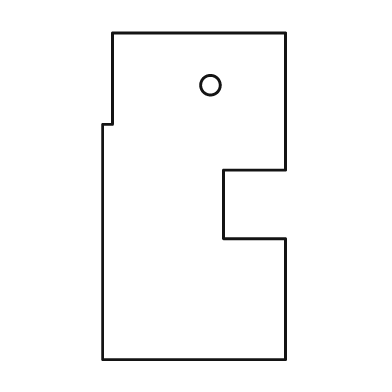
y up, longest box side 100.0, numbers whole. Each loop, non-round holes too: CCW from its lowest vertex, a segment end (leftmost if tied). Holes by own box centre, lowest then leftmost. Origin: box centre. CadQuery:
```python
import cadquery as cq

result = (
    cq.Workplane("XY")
    .moveTo(-28.0, -50.0)
    .lineTo(28.0, -50.0)
    .lineTo(28.0, -13.0)
    .lineTo(9.0, -13.0)
    .lineTo(9.0, 8.0)
    .lineTo(28.0, 8.0)
    .lineTo(28.0, 50.0)
    .lineTo(-25.0, 50.0)
    .lineTo(-25.0, 22.0)
    .lineTo(-28.0, 22.0)
    .close()
    .moveTo(5.0, 34.0)
    .circle(3.0)
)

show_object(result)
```